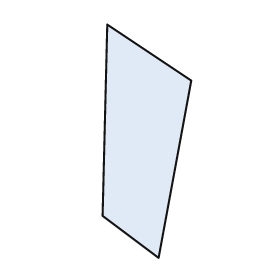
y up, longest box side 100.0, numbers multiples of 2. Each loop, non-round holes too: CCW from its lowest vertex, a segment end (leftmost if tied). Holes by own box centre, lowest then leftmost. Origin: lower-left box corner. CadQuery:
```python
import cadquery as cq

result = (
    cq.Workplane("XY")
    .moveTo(24.0, 0.0)
    .lineTo(38.0, 76.0)
    .lineTo(2.0, 100.0)
    .lineTo(0.0, 18.0)
    .close()
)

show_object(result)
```